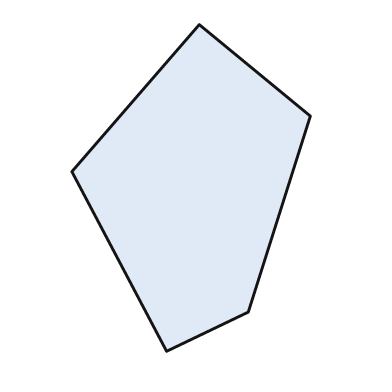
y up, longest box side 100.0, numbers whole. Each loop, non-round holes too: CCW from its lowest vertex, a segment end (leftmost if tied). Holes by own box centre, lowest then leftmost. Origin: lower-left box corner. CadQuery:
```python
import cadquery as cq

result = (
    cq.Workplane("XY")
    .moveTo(29.0, 0.0)
    .lineTo(54.0, 12.0)
    .lineTo(73.0, 72.0)
    .lineTo(39.0, 100.0)
    .lineTo(0.0, 55.0)
    .close()
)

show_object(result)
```